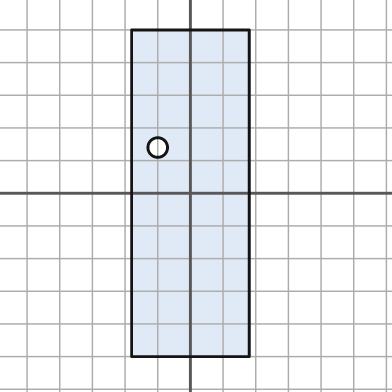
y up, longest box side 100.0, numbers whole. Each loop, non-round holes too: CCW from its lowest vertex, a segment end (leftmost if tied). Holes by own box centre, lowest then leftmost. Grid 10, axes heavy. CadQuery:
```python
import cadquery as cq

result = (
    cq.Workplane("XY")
    .moveTo(-18.0, -50.0)
    .lineTo(18.0, -50.0)
    .lineTo(18.0, 50.0)
    .lineTo(-18.0, 50.0)
    .close()
    .moveTo(-10.0, 14.0)
    .circle(3.0)
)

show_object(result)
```